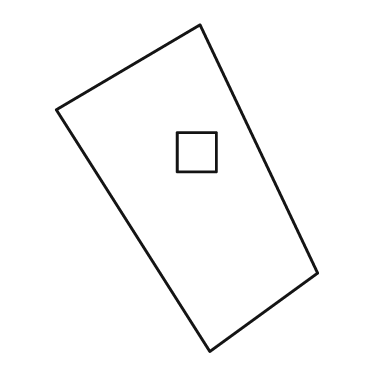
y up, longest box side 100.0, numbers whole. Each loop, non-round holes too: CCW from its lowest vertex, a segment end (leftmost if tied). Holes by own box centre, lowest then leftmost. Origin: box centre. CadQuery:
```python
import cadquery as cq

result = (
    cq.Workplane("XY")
    .moveTo(7.0, -50.0)
    .lineTo(40.0, -26.0)
    .lineTo(4.0, 50.0)
    .lineTo(-40.0, 24.0)
    .close()
    .moveTo(-3.0, 5.0)
    .lineTo(9.0, 5.0)
    .lineTo(9.0, 17.0)
    .lineTo(-3.0, 17.0)
    .close()
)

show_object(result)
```